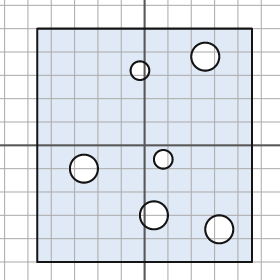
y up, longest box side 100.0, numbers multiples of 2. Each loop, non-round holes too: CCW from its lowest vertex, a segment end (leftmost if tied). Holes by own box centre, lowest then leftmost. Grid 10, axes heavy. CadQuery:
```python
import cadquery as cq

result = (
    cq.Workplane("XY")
    .moveTo(-46.0, -50.0)
    .lineTo(46.0, -50.0)
    .lineTo(46.0, 50.0)
    .lineTo(-46.0, 50.0)
    .close()
    .moveTo(32.0, -36.0)
    .circle(6.0)
    .moveTo(4.0, -30.0)
    .circle(6.0)
    .moveTo(-26.0, -10.0)
    .circle(6.0)
    .moveTo(8.0, -6.0)
    .circle(4.0)
    .moveTo(-2.0, 32.0)
    .circle(4.0)
    .moveTo(26.0, 38.0)
    .circle(6.0)
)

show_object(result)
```